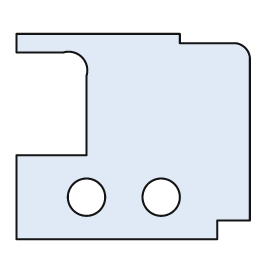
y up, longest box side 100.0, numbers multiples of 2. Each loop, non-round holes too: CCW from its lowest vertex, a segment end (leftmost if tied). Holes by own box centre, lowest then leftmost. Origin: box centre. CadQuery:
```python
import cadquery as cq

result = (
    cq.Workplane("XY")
    .moveTo(-50.0, -44.0)
    .lineTo(36.0, -44.0)
    .lineTo(36.0, -36.0)
    .lineTo(50.0, -36.0)
    .lineTo(50.0, 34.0)
    .threePointArc((48.0, 38.0), (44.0, 40.0))
    .lineTo(20.0, 40.0)
    .lineTo(20.0, 44.0)
    .lineTo(-50.0, 44.0)
    .lineTo(-50.0, 36.0)
    .lineTo(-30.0, 36.0)
    .threePointArc((-22.0, 34.0), (-20.0, 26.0))
    .lineTo(-20.0, -8.0)
    .lineTo(-50.0, -8.0)
    .close()
    .moveTo(-20.0, -26.0)
    .circle(8.0)
    .moveTo(12.0, -26.0)
    .circle(8.0)
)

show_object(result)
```